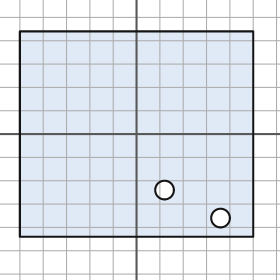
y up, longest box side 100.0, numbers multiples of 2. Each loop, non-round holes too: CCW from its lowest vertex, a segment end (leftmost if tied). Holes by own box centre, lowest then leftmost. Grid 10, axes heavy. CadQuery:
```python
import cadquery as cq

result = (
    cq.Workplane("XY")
    .moveTo(-50.0, -44.0)
    .lineTo(50.0, -44.0)
    .lineTo(50.0, 44.0)
    .lineTo(-50.0, 44.0)
    .close()
    .moveTo(36.0, -36.0)
    .circle(4.0)
    .moveTo(12.0, -24.0)
    .circle(4.0)
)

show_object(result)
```